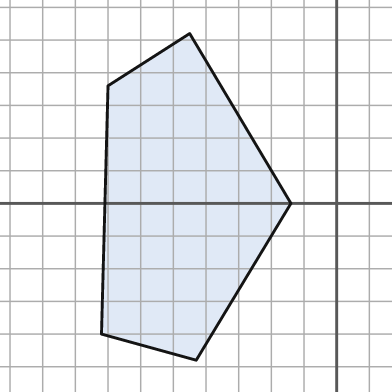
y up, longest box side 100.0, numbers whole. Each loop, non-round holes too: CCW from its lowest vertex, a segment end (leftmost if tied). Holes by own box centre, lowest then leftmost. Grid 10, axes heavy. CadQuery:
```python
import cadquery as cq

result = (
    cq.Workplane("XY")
    .moveTo(-43.0, -48.0)
    .lineTo(-14.0, 0.0)
    .lineTo(-45.0, 52.0)
    .lineTo(-70.0, 36.0)
    .lineTo(-72.0, -40.0)
    .close()
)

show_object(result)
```